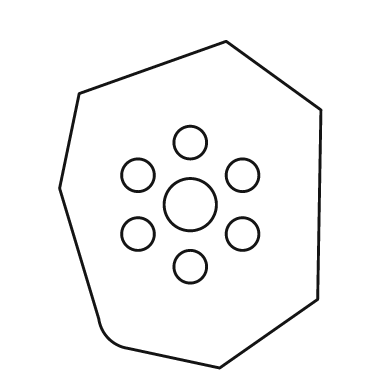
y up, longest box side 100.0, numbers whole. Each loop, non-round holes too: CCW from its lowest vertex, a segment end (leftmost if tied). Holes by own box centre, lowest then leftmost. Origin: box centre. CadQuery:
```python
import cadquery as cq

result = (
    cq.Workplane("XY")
    .moveTo(9.0, -50.0)
    .lineTo(39.0, -29.0)
    .lineTo(40.0, 29.0)
    .lineTo(11.0, 50.0)
    .lineTo(-34.0, 34.0)
    .lineTo(-40.0, 5.0)
    .lineTo(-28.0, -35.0)
    .threePointArc((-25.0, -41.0), (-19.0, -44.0))
    .close()
    .moveTo(0.0, -19.0)
    .circle(5.0)
    .moveTo(-16.0, -9.0)
    .circle(5.0)
    .moveTo(16.0, -9.0)
    .circle(5.0)
    .moveTo(0.0, 0.0)
    .circle(8.0)
    .moveTo(-16.0, 9.0)
    .circle(5.0)
    .moveTo(16.0, 9.0)
    .circle(5.0)
    .moveTo(0.0, 19.0)
    .circle(5.0)
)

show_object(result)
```